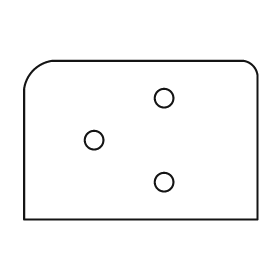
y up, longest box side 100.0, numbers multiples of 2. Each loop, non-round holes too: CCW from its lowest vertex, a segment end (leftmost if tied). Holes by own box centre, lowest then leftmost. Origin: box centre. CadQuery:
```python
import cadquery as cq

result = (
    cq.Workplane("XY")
    .moveTo(-50.0, -34.0)
    .lineTo(50.0, -34.0)
    .lineTo(50.0, 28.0)
    .threePointArc((48.0, 32.0), (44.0, 34.0))
    .lineTo(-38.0, 34.0)
    .threePointArc((-46.0, 30.0), (-50.0, 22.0))
    .close()
    .moveTo(10.0, -18.0)
    .circle(4.0)
    .moveTo(-20.0, 0.0)
    .circle(4.0)
    .moveTo(10.0, 18.0)
    .circle(4.0)
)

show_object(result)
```